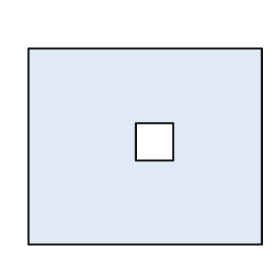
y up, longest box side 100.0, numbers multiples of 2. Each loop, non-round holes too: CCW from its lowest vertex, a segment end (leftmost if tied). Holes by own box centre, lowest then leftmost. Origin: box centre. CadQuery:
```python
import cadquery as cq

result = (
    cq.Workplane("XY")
    .moveTo(-50.0, -42.0)
    .lineTo(50.0, -42.0)
    .lineTo(50.0, 42.0)
    .lineTo(-50.0, 42.0)
    .close()
    .moveTo(-4.0, -6.0)
    .lineTo(12.0, -6.0)
    .lineTo(12.0, 10.0)
    .lineTo(-4.0, 10.0)
    .close()
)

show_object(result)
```